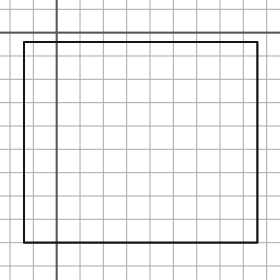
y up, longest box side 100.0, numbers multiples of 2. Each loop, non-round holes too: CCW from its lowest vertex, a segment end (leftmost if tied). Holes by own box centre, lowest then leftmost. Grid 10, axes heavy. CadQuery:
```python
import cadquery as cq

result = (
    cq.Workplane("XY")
    .moveTo(-14.0, -90.0)
    .lineTo(86.0, -90.0)
    .lineTo(86.0, -4.0)
    .lineTo(-14.0, -4.0)
    .close()
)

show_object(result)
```